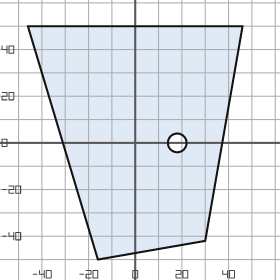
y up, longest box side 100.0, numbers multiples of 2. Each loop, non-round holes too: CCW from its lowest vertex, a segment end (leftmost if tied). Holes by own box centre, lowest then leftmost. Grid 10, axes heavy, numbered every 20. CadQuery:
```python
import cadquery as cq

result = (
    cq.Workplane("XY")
    .moveTo(-16.0, -50.0)
    .lineTo(30.0, -42.0)
    .lineTo(46.0, 50.0)
    .lineTo(-46.0, 50.0)
    .close()
    .moveTo(18.0, 0.0)
    .circle(4.0)
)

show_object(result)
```